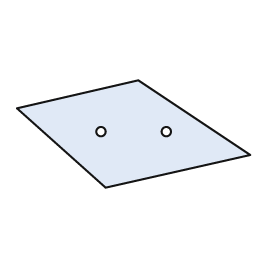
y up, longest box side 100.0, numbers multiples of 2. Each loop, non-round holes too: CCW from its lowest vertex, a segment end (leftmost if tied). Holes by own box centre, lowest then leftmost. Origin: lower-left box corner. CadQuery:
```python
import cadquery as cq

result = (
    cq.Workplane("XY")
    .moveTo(38.0, 0.0)
    .lineTo(100.0, 14.0)
    .lineTo(52.0, 46.0)
    .lineTo(0.0, 34.0)
    .close()
    .moveTo(36.0, 24.0)
    .circle(2.0)
    .moveTo(64.0, 24.0)
    .circle(2.0)
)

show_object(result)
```